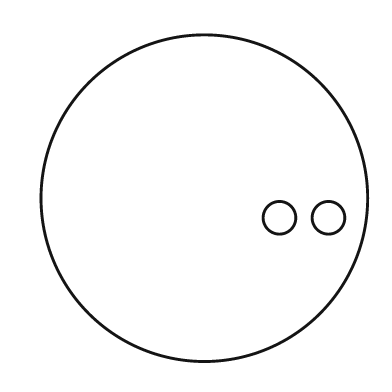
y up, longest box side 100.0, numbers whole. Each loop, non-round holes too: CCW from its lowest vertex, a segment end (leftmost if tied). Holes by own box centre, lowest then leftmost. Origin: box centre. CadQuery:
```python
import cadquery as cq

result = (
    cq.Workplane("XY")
    .moveTo(0.0, 0.0)
    .circle(50.0)
    .moveTo(23.0, -6.0)
    .circle(5.0)
    .moveTo(38.0, -6.0)
    .circle(5.0)
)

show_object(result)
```